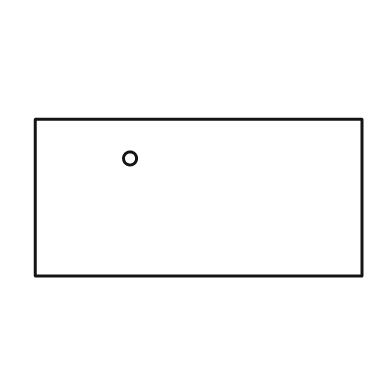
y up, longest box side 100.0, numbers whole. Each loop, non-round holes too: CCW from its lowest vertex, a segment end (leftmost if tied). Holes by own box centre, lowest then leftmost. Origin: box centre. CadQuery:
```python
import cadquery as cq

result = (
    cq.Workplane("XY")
    .moveTo(-50.0, -24.0)
    .lineTo(50.0, -24.0)
    .lineTo(50.0, 24.0)
    .lineTo(-50.0, 24.0)
    .close()
    .moveTo(-21.0, 12.0)
    .circle(2.0)
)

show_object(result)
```